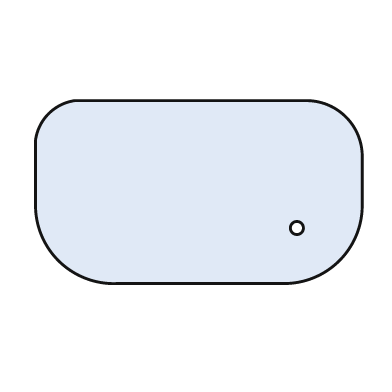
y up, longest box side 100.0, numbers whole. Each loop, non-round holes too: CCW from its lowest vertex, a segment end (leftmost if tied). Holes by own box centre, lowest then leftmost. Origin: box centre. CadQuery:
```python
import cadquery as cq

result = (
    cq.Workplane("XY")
    .moveTo(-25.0, -28.0)
    .lineTo(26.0, -28.0)
    .threePointArc((43.0, -21.0), (50.0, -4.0))
    .lineTo(50.0, 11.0)
    .threePointArc((45.0, 23.0), (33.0, 28.0))
    .lineTo(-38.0, 28.0)
    .threePointArc((-46.0, 24.0), (-50.0, 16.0))
    .lineTo(-50.0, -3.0)
    .threePointArc((-43.0, -21.0), (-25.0, -28.0))
    .close()
    .moveTo(30.0, -11.0)
    .circle(2.0)
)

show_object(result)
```